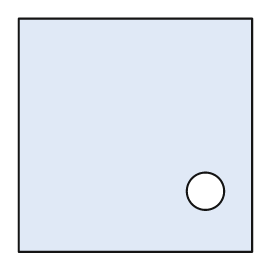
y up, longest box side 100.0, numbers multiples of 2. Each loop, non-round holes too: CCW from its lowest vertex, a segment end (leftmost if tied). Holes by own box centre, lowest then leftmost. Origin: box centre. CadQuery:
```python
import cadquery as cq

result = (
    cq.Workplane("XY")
    .moveTo(-50.0, -50.0)
    .lineTo(50.0, -50.0)
    .lineTo(50.0, 50.0)
    .lineTo(-50.0, 50.0)
    .close()
    .moveTo(30.0, -24.0)
    .circle(8.0)
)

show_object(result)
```